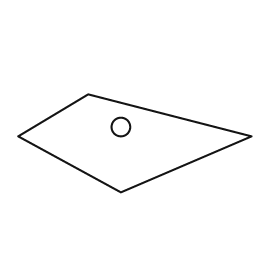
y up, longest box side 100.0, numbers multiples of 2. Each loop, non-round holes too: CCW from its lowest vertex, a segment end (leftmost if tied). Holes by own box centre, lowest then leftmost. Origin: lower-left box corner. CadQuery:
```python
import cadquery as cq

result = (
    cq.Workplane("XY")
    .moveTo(44.0, 0.0)
    .lineTo(100.0, 24.0)
    .lineTo(30.0, 42.0)
    .lineTo(0.0, 24.0)
    .close()
    .moveTo(44.0, 28.0)
    .circle(4.0)
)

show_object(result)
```